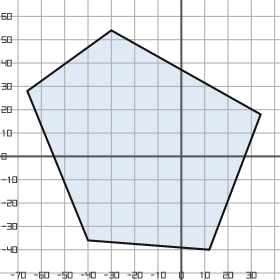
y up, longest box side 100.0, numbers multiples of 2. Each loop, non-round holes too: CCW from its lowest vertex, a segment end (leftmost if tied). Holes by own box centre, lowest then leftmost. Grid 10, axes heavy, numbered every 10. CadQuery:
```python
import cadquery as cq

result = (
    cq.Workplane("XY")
    .moveTo(12.0, -40.0)
    .lineTo(34.0, 18.0)
    .lineTo(-30.0, 54.0)
    .lineTo(-66.0, 28.0)
    .lineTo(-40.0, -36.0)
    .close()
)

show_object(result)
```